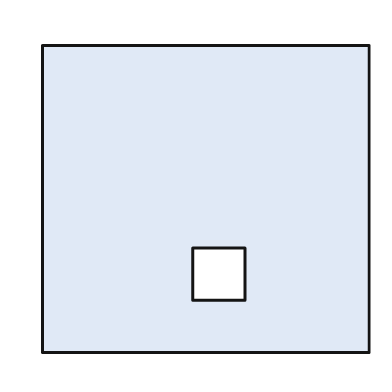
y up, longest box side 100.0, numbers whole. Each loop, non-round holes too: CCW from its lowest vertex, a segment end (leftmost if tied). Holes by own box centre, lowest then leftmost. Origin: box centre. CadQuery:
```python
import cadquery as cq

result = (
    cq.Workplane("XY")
    .moveTo(-50.0, -47.0)
    .lineTo(50.0, -47.0)
    .lineTo(50.0, 47.0)
    .lineTo(-50.0, 47.0)
    .close()
    .moveTo(-4.0, -31.0)
    .lineTo(12.0, -31.0)
    .lineTo(12.0, -15.0)
    .lineTo(-4.0, -15.0)
    .close()
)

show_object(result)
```